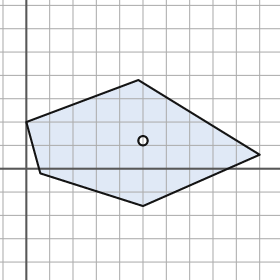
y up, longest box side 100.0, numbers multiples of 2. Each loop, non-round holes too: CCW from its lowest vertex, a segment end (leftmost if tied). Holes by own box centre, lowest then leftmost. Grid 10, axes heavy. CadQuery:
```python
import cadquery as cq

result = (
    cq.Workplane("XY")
    .moveTo(50.0, -16.0)
    .lineTo(100.0, 6.0)
    .lineTo(48.0, 38.0)
    .lineTo(0.0, 20.0)
    .lineTo(6.0, -2.0)
    .close()
    .moveTo(50.0, 12.0)
    .circle(2.0)
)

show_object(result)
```